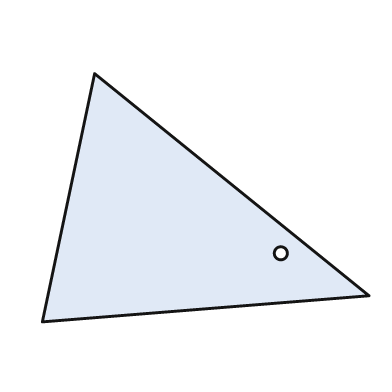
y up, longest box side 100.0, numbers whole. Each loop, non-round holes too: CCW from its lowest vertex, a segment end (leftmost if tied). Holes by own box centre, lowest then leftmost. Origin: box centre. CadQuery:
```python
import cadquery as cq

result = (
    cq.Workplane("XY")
    .moveTo(-50.0, -38.0)
    .lineTo(50.0, -30.0)
    .lineTo(-34.0, 38.0)
    .close()
    .moveTo(23.0, -17.0)
    .circle(2.0)
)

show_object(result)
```